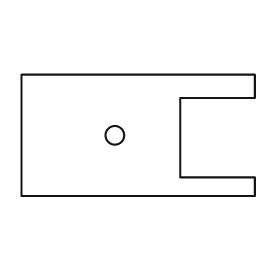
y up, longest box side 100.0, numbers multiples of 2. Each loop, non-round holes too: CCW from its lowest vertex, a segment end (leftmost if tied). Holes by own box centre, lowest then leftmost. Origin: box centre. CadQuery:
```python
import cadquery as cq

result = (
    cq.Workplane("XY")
    .moveTo(-50.0, -26.0)
    .lineTo(50.0, -26.0)
    .lineTo(50.0, -18.0)
    .lineTo(18.0, -18.0)
    .lineTo(18.0, 16.0)
    .lineTo(50.0, 16.0)
    .lineTo(50.0, 26.0)
    .lineTo(-50.0, 26.0)
    .close()
    .moveTo(-10.0, 0.0)
    .circle(4.0)
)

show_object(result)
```